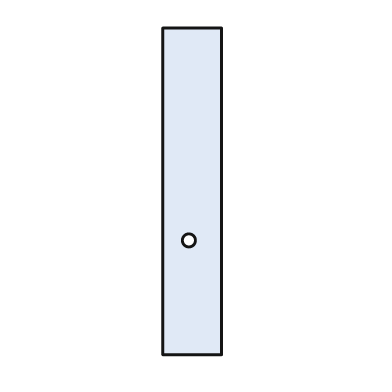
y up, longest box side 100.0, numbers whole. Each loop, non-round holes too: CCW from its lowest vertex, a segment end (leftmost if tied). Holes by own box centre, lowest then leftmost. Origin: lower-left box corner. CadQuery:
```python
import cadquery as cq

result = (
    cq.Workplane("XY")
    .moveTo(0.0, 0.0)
    .lineTo(18.0, 0.0)
    .lineTo(18.0, 100.0)
    .lineTo(0.0, 100.0)
    .close()
    .moveTo(8.0, 35.0)
    .circle(2.0)
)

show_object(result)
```